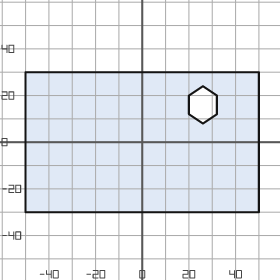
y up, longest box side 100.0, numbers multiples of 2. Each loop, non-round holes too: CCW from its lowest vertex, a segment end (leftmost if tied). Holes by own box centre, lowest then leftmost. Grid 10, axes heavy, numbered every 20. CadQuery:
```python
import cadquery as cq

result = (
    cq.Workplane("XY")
    .moveTo(-50.0, -30.0)
    .lineTo(50.0, -30.0)
    .lineTo(50.0, 30.0)
    .lineTo(-50.0, 30.0)
    .close()
    .moveTo(26.0, 8.0)
    .lineTo(32.0, 12.0)
    .lineTo(32.0, 20.0)
    .lineTo(26.0, 24.0)
    .lineTo(20.0, 20.0)
    .lineTo(20.0, 12.0)
    .close()
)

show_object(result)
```